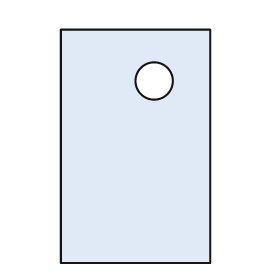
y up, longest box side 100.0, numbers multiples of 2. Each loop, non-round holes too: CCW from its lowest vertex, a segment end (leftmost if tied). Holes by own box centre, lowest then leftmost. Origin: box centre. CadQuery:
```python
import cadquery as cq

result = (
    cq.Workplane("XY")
    .moveTo(-32.0, -50.0)
    .lineTo(32.0, -50.0)
    .lineTo(32.0, 50.0)
    .lineTo(-32.0, 50.0)
    .close()
    .moveTo(8.0, 28.0)
    .circle(8.0)
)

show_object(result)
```